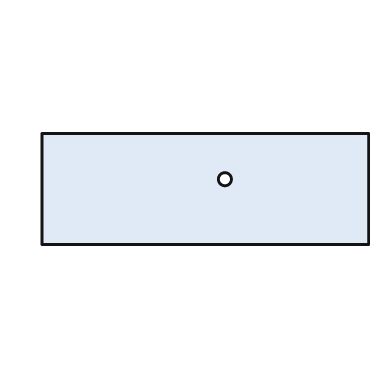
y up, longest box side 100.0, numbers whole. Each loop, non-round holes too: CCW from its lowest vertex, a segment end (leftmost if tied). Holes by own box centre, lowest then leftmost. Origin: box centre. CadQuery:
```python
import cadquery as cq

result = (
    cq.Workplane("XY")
    .moveTo(-50.0, -17.0)
    .lineTo(50.0, -17.0)
    .lineTo(50.0, 17.0)
    .lineTo(-50.0, 17.0)
    .close()
    .moveTo(6.0, 3.0)
    .circle(2.0)
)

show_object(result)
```